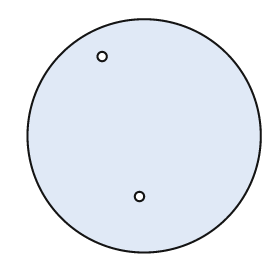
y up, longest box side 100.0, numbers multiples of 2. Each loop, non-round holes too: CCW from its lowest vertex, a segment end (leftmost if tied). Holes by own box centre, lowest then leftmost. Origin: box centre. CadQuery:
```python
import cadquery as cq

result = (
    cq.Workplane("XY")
    .moveTo(0.0, 0.0)
    .circle(50.0)
    .moveTo(-2.0, -26.0)
    .circle(2.0)
    .moveTo(-18.0, 34.0)
    .circle(2.0)
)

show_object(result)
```